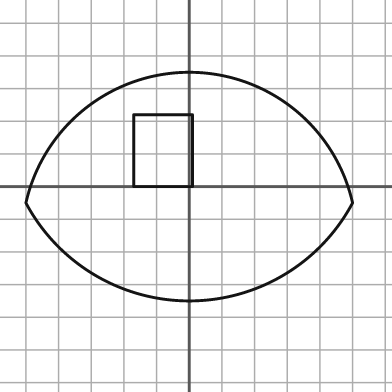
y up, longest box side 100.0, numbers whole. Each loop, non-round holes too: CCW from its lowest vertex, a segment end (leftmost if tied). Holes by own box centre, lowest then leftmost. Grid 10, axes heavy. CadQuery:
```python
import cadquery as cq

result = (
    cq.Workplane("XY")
    .moveTo(-50.0, -5.0)
    .threePointArc((0.0, -35.0), (50.0, -5.0))
    .threePointArc((0.0, 35.0), (-50.0, -5.0))
    .close()
    .moveTo(-17.0, 0.0)
    .lineTo(1.0, 0.0)
    .lineTo(1.0, 22.0)
    .lineTo(-17.0, 22.0)
    .close()
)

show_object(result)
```